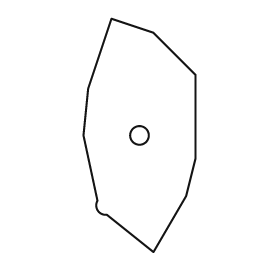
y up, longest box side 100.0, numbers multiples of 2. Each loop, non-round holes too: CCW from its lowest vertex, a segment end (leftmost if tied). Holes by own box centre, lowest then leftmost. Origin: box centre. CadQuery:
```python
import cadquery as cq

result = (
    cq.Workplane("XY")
    .moveTo(6.0, -50.0)
    .lineTo(20.0, -26.0)
    .lineTo(24.0, -10.0)
    .lineTo(24.0, 26.0)
    .lineTo(6.0, 44.0)
    .lineTo(-12.0, 50.0)
    .lineTo(-22.0, 20.0)
    .lineTo(-24.0, 0.0)
    .lineTo(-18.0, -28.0)
    .threePointArc((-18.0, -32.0), (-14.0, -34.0))
    .close()
    .moveTo(0.0, 0.0)
    .circle(4.0)
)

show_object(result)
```